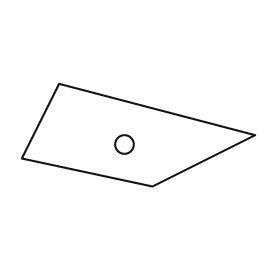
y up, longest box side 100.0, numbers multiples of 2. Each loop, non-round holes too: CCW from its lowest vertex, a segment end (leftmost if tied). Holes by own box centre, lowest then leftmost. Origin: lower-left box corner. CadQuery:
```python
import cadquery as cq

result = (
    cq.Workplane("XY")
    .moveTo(56.0, 0.0)
    .lineTo(100.0, 22.0)
    .lineTo(16.0, 44.0)
    .lineTo(0.0, 12.0)
    .close()
    .moveTo(44.0, 18.0)
    .circle(4.0)
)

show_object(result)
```